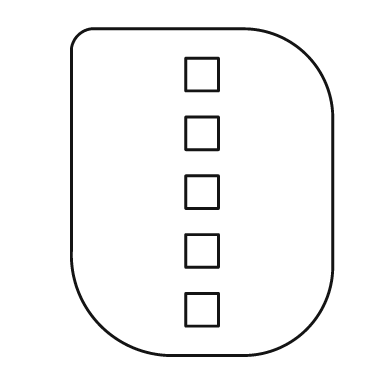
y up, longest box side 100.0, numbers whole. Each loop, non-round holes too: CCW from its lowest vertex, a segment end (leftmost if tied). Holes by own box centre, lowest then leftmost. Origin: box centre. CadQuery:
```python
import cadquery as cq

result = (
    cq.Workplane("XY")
    .moveTo(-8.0, -50.0)
    .lineTo(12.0, -50.0)
    .threePointArc((32.0, -42.0), (40.0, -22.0))
    .lineTo(40.0, 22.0)
    .threePointArc((32.0, 42.0), (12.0, 50.0))
    .lineTo(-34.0, 50.0)
    .threePointArc((-38.0, 48.0), (-40.0, 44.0))
    .lineTo(-40.0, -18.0)
    .threePointArc((-31.0, -41.0), (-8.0, -50.0))
    .close()
    .moveTo(-5.0, -41.0)
    .lineTo(5.0, -41.0)
    .lineTo(5.0, -31.0)
    .lineTo(-5.0, -31.0)
    .close()
    .moveTo(-5.0, -23.0)
    .lineTo(5.0, -23.0)
    .lineTo(5.0, -13.0)
    .lineTo(-5.0, -13.0)
    .close()
    .moveTo(-5.0, -5.0)
    .lineTo(5.0, -5.0)
    .lineTo(5.0, 5.0)
    .lineTo(-5.0, 5.0)
    .close()
    .moveTo(-5.0, 13.0)
    .lineTo(5.0, 13.0)
    .lineTo(5.0, 23.0)
    .lineTo(-5.0, 23.0)
    .close()
    .moveTo(-5.0, 31.0)
    .lineTo(5.0, 31.0)
    .lineTo(5.0, 41.0)
    .lineTo(-5.0, 41.0)
    .close()
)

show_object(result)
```